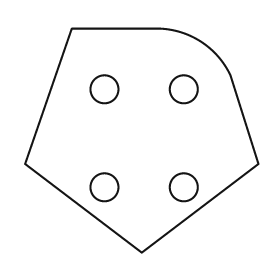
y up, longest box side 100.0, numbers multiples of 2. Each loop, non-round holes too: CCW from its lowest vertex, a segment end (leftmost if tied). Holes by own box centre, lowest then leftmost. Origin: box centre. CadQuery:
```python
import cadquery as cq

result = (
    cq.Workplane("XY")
    .moveTo(0.0, -48.0)
    .lineTo(50.0, -10.0)
    .lineTo(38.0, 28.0)
    .threePointArc((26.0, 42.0), (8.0, 48.0))
    .lineTo(-30.0, 48.0)
    .lineTo(-50.0, -10.0)
    .close()
    .moveTo(-16.0, -20.0)
    .circle(6.0)
    .moveTo(18.0, -20.0)
    .circle(6.0)
    .moveTo(-16.0, 22.0)
    .circle(6.0)
    .moveTo(18.0, 22.0)
    .circle(6.0)
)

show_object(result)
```